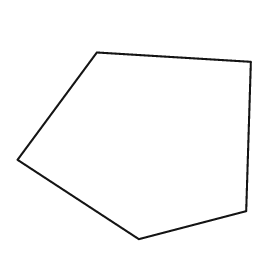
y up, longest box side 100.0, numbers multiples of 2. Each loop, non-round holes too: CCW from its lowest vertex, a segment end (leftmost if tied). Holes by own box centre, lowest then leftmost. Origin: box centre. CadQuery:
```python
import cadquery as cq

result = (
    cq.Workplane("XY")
    .moveTo(2.0, -40.0)
    .lineTo(48.0, -28.0)
    .lineTo(50.0, 36.0)
    .lineTo(-16.0, 40.0)
    .lineTo(-50.0, -6.0)
    .close()
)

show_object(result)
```